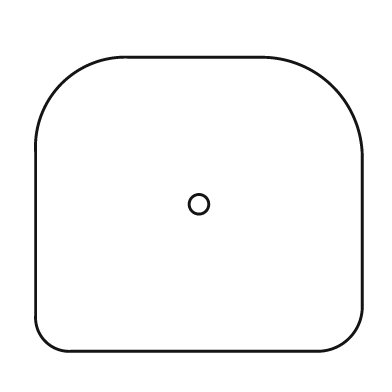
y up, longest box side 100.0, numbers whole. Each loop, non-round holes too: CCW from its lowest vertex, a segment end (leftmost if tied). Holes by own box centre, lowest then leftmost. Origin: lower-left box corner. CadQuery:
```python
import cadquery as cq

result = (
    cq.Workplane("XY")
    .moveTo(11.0, 0.0)
    .lineTo(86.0, 0.0)
    .threePointArc((96.0, 4.0), (100.0, 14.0))
    .lineTo(100.0, 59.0)
    .threePointArc((91.0, 81.0), (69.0, 90.0))
    .lineTo(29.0, 90.0)
    .threePointArc((8.0, 82.0), (0.0, 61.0))
    .lineTo(0.0, 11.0)
    .threePointArc((3.0, 3.0), (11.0, 0.0))
    .close()
    .moveTo(50.0, 45.0)
    .circle(3.0)
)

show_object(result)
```